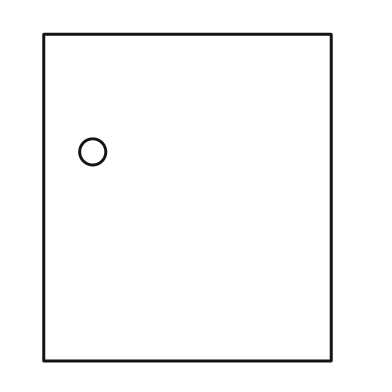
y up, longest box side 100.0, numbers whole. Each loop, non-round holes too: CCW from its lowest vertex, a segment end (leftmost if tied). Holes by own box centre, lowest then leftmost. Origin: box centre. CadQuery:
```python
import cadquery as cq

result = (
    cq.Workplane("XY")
    .moveTo(-44.0, -50.0)
    .lineTo(44.0, -50.0)
    .lineTo(44.0, 50.0)
    .lineTo(-44.0, 50.0)
    .close()
    .moveTo(-29.0, 14.0)
    .circle(4.0)
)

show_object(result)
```